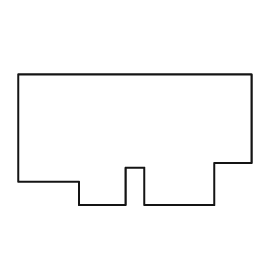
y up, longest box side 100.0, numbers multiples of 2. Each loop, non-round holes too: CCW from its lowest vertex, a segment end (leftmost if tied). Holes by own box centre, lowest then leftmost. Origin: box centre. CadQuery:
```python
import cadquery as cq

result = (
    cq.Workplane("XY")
    .moveTo(-24.0, -28.0)
    .lineTo(-4.0, -28.0)
    .lineTo(-4.0, -12.0)
    .lineTo(4.0, -12.0)
    .lineTo(4.0, -28.0)
    .lineTo(34.0, -28.0)
    .lineTo(34.0, -10.0)
    .lineTo(50.0, -10.0)
    .lineTo(50.0, 28.0)
    .lineTo(-50.0, 28.0)
    .lineTo(-50.0, -18.0)
    .lineTo(-24.0, -18.0)
    .close()
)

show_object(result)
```